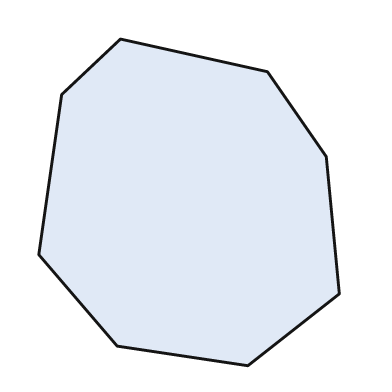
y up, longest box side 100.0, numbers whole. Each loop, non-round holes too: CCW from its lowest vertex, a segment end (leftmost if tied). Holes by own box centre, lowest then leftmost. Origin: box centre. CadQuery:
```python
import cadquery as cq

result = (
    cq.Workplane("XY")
    .moveTo(18.0, -50.0)
    .lineTo(46.0, -28.0)
    .lineTo(42.0, 14.0)
    .lineTo(24.0, 40.0)
    .lineTo(-21.0, 50.0)
    .lineTo(-39.0, 33.0)
    .lineTo(-46.0, -16.0)
    .lineTo(-22.0, -44.0)
    .close()
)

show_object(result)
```